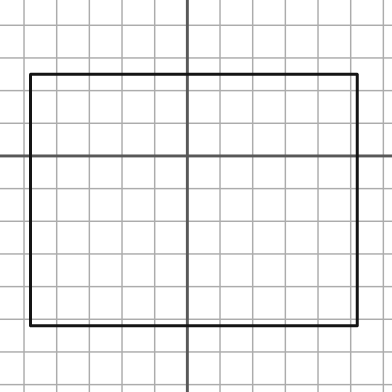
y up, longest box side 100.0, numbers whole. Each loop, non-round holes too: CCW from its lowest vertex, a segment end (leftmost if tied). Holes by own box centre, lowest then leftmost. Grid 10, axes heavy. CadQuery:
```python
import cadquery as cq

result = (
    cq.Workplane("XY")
    .moveTo(-48.0, -52.0)
    .lineTo(52.0, -52.0)
    .lineTo(52.0, 25.0)
    .lineTo(-48.0, 25.0)
    .close()
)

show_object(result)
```